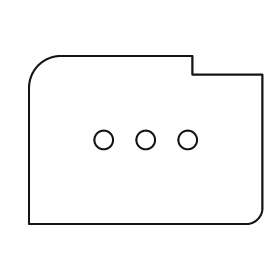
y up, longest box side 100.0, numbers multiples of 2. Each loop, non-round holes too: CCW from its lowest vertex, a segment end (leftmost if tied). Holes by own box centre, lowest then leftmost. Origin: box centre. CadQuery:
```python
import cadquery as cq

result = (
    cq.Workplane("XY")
    .moveTo(-50.0, -36.0)
    .lineTo(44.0, -36.0)
    .threePointArc((48.0, -34.0), (50.0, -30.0))
    .lineTo(50.0, 28.0)
    .lineTo(20.0, 28.0)
    .lineTo(20.0, 36.0)
    .lineTo(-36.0, 36.0)
    .threePointArc((-46.0, 32.0), (-50.0, 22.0))
    .close()
    .moveTo(-18.0, 0.0)
    .circle(4.0)
    .moveTo(0.0, 0.0)
    .circle(4.0)
    .moveTo(18.0, 0.0)
    .circle(4.0)
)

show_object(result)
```